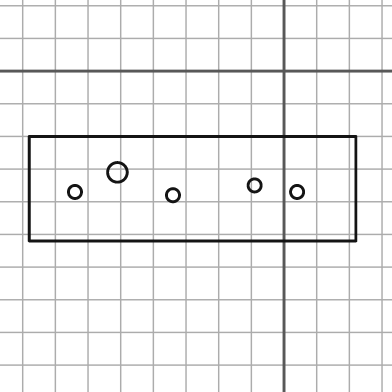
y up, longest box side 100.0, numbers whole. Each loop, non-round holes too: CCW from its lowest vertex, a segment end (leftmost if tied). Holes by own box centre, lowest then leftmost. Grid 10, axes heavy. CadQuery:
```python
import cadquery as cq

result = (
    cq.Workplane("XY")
    .moveTo(-78.0, -52.0)
    .lineTo(22.0, -52.0)
    .lineTo(22.0, -20.0)
    .lineTo(-78.0, -20.0)
    .close()
    .moveTo(-34.0, -38.0)
    .circle(2.0)
    .moveTo(-64.0, -37.0)
    .circle(2.0)
    .moveTo(4.0, -37.0)
    .circle(2.0)
    .moveTo(-9.0, -35.0)
    .circle(2.0)
    .moveTo(-51.0, -31.0)
    .circle(3.0)
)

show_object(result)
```